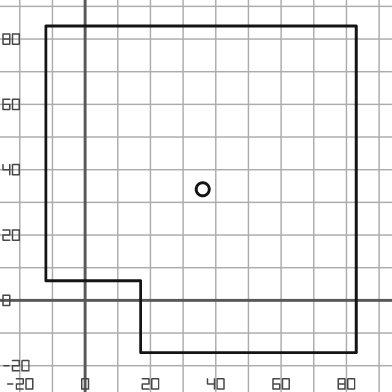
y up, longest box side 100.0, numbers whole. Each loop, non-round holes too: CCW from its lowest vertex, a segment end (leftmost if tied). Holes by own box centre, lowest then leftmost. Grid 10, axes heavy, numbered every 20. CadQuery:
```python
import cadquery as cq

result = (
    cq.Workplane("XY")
    .moveTo(17.0, -16.0)
    .lineTo(83.0, -16.0)
    .lineTo(83.0, 84.0)
    .lineTo(-12.0, 84.0)
    .lineTo(-12.0, 6.0)
    .lineTo(17.0, 6.0)
    .close()
    .moveTo(36.0, 34.0)
    .circle(2.0)
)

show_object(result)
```